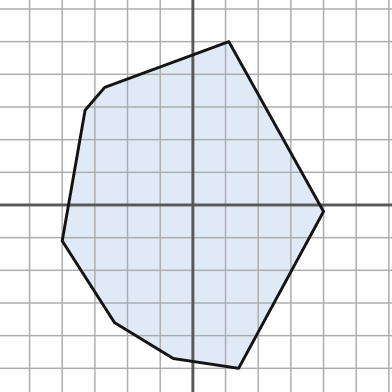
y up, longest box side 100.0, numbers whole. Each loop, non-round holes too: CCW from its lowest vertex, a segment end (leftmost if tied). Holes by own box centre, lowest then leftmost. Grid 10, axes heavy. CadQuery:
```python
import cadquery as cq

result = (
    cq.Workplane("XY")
    .moveTo(14.0, -50.0)
    .lineTo(40.0, -2.0)
    .lineTo(11.0, 50.0)
    .lineTo(-27.0, 36.0)
    .lineTo(-33.0, 29.0)
    .lineTo(-40.0, -11.0)
    .lineTo(-24.0, -36.0)
    .lineTo(-6.0, -47.0)
    .close()
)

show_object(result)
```